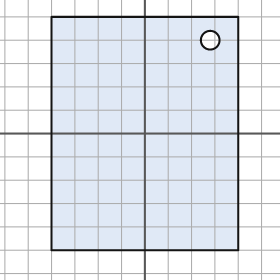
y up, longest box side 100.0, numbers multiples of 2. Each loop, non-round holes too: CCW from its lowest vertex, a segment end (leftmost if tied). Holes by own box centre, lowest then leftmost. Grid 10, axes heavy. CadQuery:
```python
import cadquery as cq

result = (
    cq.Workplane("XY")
    .moveTo(-40.0, -50.0)
    .lineTo(40.0, -50.0)
    .lineTo(40.0, 50.0)
    .lineTo(-40.0, 50.0)
    .close()
    .moveTo(28.0, 40.0)
    .circle(4.0)
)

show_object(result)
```